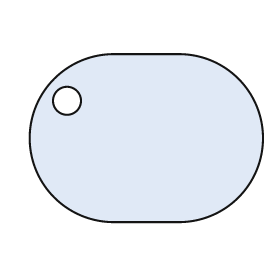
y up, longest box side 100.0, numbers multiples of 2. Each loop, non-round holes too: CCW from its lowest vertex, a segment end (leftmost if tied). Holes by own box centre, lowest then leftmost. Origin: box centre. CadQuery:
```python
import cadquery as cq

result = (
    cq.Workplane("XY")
    .moveTo(-14.0, -36.0)
    .lineTo(14.0, -36.0)
    .threePointArc((50.0, 0.0), (14.0, 36.0))
    .lineTo(-14.0, 36.0)
    .threePointArc((-50.0, 0.0), (-14.0, -36.0))
    .close()
    .moveTo(-34.0, 16.0)
    .circle(6.0)
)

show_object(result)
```